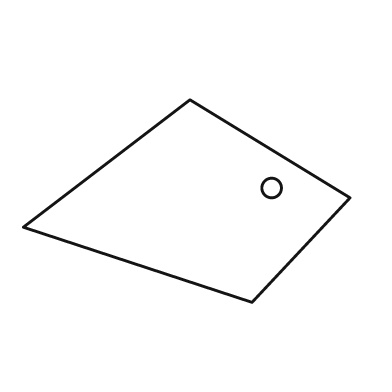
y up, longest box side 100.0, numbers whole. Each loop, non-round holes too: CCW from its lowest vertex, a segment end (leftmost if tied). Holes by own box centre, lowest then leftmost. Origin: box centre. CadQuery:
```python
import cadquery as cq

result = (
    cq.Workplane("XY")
    .moveTo(20.0, -31.0)
    .lineTo(50.0, 1.0)
    .lineTo(1.0, 31.0)
    .lineTo(-50.0, -8.0)
    .close()
    .moveTo(26.0, 4.0)
    .circle(3.0)
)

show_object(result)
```